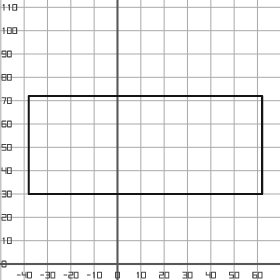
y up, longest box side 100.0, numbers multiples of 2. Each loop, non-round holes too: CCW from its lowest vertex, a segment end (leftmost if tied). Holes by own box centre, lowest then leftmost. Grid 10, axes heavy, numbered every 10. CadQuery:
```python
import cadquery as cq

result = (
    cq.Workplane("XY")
    .moveTo(-38.0, 30.0)
    .lineTo(62.0, 30.0)
    .lineTo(62.0, 72.0)
    .lineTo(-38.0, 72.0)
    .close()
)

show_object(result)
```